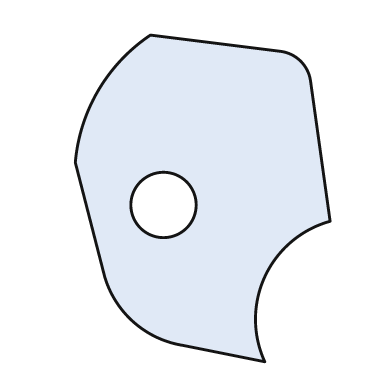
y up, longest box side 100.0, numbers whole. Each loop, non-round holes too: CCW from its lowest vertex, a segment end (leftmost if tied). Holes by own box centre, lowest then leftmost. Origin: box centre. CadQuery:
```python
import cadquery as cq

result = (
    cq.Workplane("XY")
    .moveTo(19.0, -50.0)
    .threePointArc((19.0, -24.0), (39.0, -7.0))
    .lineTo(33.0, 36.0)
    .threePointArc((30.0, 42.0), (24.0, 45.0))
    .lineTo(-16.0, 50.0)
    .threePointArc((-32.0, 33.0), (-39.0, 11.0))
    .lineTo(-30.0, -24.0)
    .threePointArc((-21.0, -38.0), (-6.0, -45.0))
    .close()
    .moveTo(-12.0, -2.0)
    .circle(10.0)
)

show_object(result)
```